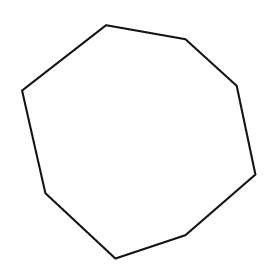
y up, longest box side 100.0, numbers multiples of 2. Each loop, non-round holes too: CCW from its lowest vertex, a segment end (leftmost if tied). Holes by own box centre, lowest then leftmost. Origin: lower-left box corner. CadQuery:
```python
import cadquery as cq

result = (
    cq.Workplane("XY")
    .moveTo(40.0, 0.0)
    .lineTo(70.0, 10.0)
    .lineTo(100.0, 36.0)
    .lineTo(92.0, 74.0)
    .lineTo(70.0, 94.0)
    .lineTo(36.0, 100.0)
    .lineTo(0.0, 72.0)
    .lineTo(10.0, 28.0)
    .close()
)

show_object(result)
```